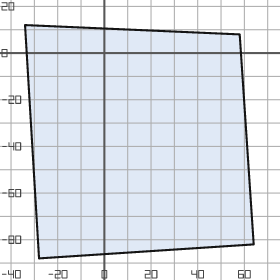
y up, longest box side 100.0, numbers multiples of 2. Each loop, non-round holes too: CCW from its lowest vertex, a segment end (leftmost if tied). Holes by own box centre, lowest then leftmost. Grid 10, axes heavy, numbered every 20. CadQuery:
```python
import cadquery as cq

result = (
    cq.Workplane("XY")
    .moveTo(-28.0, -88.0)
    .lineTo(64.0, -82.0)
    .lineTo(58.0, 8.0)
    .lineTo(-34.0, 12.0)
    .close()
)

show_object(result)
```